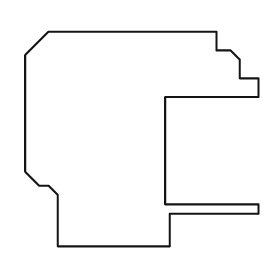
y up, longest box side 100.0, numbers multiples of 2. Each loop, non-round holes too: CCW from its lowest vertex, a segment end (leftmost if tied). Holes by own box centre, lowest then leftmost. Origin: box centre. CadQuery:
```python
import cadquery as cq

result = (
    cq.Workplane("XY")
    .moveTo(-36.0, -46.0)
    .lineTo(12.0, -46.0)
    .lineTo(12.0, -32.0)
    .lineTo(50.0, -32.0)
    .lineTo(50.0, -28.0)
    .lineTo(10.0, -28.0)
    .lineTo(10.0, 18.0)
    .lineTo(50.0, 18.0)
    .lineTo(50.0, 26.0)
    .lineTo(42.0, 26.0)
    .lineTo(42.0, 34.0)
    .lineTo(38.0, 38.0)
    .lineTo(32.0, 38.0)
    .lineTo(32.0, 46.0)
    .lineTo(-40.0, 46.0)
    .lineTo(-50.0, 36.0)
    .lineTo(-50.0, -14.0)
    .lineTo(-44.0, -20.0)
    .lineTo(-40.0, -20.0)
    .lineTo(-36.0, -24.0)
    .close()
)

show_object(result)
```